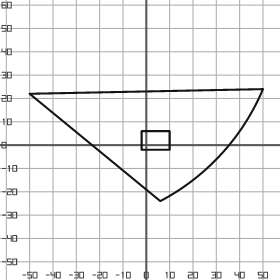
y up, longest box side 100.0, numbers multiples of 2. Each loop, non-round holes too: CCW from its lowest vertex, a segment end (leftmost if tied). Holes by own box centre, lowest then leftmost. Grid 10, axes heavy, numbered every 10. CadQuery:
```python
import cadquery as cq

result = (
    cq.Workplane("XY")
    .moveTo(6.0, -24.0)
    .threePointArc((32.0, -4.0), (50.0, 24.0))
    .lineTo(-50.0, 22.0)
    .close()
    .moveTo(-2.0, -2.0)
    .lineTo(10.0, -2.0)
    .lineTo(10.0, 6.0)
    .lineTo(-2.0, 6.0)
    .close()
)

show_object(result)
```